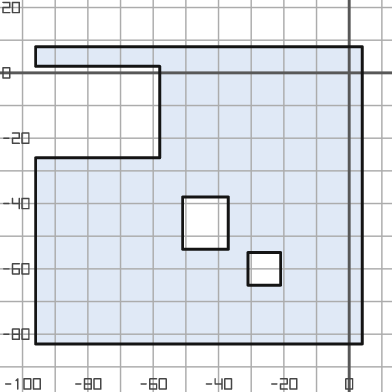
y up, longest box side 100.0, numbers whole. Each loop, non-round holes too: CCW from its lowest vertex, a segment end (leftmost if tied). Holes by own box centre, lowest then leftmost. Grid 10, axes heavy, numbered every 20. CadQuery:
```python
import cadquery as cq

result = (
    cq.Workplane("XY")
    .moveTo(-96.0, -83.0)
    .lineTo(4.0, -83.0)
    .lineTo(4.0, 8.0)
    .lineTo(-96.0, 8.0)
    .lineTo(-96.0, 2.0)
    .lineTo(-58.0, 2.0)
    .lineTo(-58.0, -26.0)
    .lineTo(-96.0, -26.0)
    .close()
    .moveTo(-31.0, -65.0)
    .lineTo(-21.0, -65.0)
    .lineTo(-21.0, -55.0)
    .lineTo(-31.0, -55.0)
    .close()
    .moveTo(-51.0, -54.0)
    .lineTo(-37.0, -54.0)
    .lineTo(-37.0, -38.0)
    .lineTo(-51.0, -38.0)
    .close()
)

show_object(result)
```